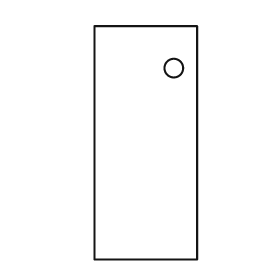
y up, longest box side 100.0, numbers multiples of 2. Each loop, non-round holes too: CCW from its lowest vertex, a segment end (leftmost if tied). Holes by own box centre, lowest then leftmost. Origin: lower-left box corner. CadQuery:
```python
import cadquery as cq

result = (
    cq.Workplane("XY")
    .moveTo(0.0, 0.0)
    .lineTo(44.0, 0.0)
    .lineTo(44.0, 100.0)
    .lineTo(0.0, 100.0)
    .close()
    .moveTo(34.0, 82.0)
    .circle(4.0)
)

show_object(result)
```